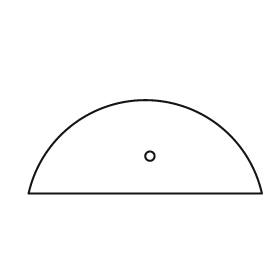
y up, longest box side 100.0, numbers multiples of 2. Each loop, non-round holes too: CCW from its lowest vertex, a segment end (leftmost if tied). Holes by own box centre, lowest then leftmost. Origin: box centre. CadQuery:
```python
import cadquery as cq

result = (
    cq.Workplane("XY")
    .moveTo(-50.0, -20.0)
    .lineTo(50.0, -20.0)
    .threePointArc((0.0, 20.0), (-50.0, -20.0))
    .close()
    .moveTo(2.0, -4.0)
    .circle(2.0)
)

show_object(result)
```